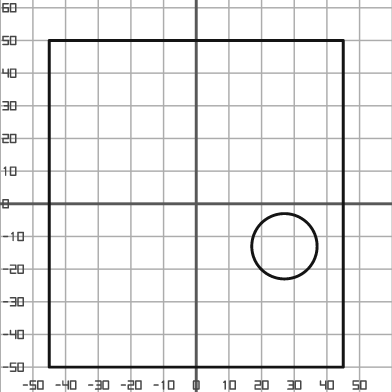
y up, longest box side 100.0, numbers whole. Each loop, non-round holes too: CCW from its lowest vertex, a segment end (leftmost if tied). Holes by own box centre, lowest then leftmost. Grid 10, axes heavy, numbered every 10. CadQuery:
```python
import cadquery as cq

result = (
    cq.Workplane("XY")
    .moveTo(-45.0, -50.0)
    .lineTo(45.0, -50.0)
    .lineTo(45.0, 50.0)
    .lineTo(-45.0, 50.0)
    .close()
    .moveTo(27.0, -13.0)
    .circle(10.0)
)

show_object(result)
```